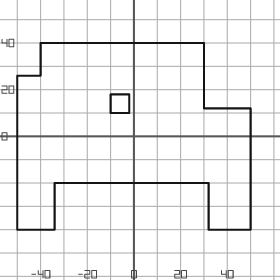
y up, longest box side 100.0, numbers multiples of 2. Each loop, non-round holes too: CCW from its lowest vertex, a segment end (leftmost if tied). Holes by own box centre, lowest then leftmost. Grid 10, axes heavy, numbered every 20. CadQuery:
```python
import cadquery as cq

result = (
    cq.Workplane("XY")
    .moveTo(-50.0, -40.0)
    .lineTo(-34.0, -40.0)
    .lineTo(-34.0, -20.0)
    .lineTo(32.0, -20.0)
    .lineTo(32.0, -40.0)
    .lineTo(50.0, -40.0)
    .lineTo(50.0, 12.0)
    .lineTo(30.0, 12.0)
    .lineTo(30.0, 40.0)
    .lineTo(-40.0, 40.0)
    .lineTo(-40.0, 26.0)
    .lineTo(-50.0, 26.0)
    .close()
    .moveTo(-10.0, 10.0)
    .lineTo(-2.0, 10.0)
    .lineTo(-2.0, 18.0)
    .lineTo(-10.0, 18.0)
    .close()
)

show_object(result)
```